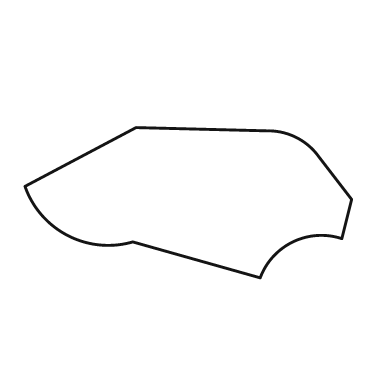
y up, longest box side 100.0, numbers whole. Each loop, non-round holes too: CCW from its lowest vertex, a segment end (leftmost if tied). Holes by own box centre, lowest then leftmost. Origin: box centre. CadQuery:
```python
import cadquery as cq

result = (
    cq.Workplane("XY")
    .moveTo(22.0, -23.0)
    .threePointArc((32.0, -12.0), (47.0, -11.0))
    .lineTo(50.0, 1.0)
    .lineTo(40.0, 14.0)
    .threePointArc((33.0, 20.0), (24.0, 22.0))
    .lineTo(-16.0, 23.0)
    .lineTo(-50.0, 5.0)
    .threePointArc((-37.0, -10.0), (-17.0, -12.0))
    .close()
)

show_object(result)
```